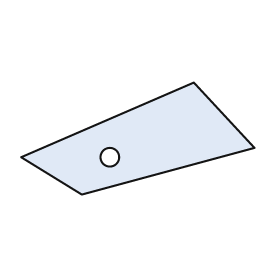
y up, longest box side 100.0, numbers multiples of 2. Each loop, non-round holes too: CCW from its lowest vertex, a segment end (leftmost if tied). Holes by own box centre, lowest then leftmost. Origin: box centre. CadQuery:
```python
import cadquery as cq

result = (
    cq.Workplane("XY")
    .moveTo(-24.0, -24.0)
    .lineTo(50.0, -4.0)
    .lineTo(24.0, 24.0)
    .lineTo(-50.0, -8.0)
    .close()
    .moveTo(-12.0, -8.0)
    .circle(4.0)
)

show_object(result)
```